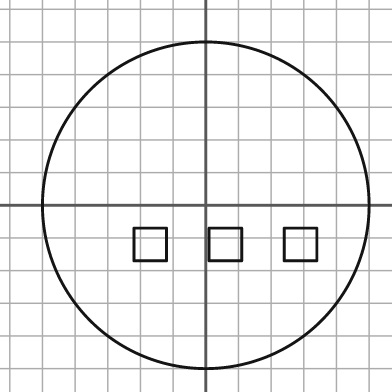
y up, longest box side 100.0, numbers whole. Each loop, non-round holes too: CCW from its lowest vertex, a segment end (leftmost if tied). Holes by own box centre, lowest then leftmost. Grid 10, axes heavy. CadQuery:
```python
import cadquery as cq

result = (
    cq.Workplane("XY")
    .moveTo(0.0, 0.0)
    .circle(50.0)
    .moveTo(-22.0, -17.0)
    .lineTo(-12.0, -17.0)
    .lineTo(-12.0, -7.0)
    .lineTo(-22.0, -7.0)
    .close()
    .moveTo(1.0, -17.0)
    .lineTo(11.0, -17.0)
    .lineTo(11.0, -7.0)
    .lineTo(1.0, -7.0)
    .close()
    .moveTo(24.0, -17.0)
    .lineTo(34.0, -17.0)
    .lineTo(34.0, -7.0)
    .lineTo(24.0, -7.0)
    .close()
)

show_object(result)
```